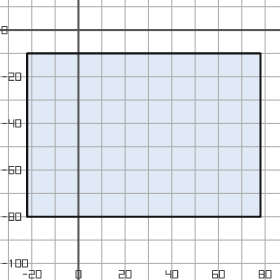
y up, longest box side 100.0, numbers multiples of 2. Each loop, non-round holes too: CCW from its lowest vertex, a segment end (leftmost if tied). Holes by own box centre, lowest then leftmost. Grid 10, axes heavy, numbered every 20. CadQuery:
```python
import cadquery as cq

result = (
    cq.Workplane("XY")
    .moveTo(-22.0, -80.0)
    .lineTo(78.0, -80.0)
    .lineTo(78.0, -10.0)
    .lineTo(-22.0, -10.0)
    .close()
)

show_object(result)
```